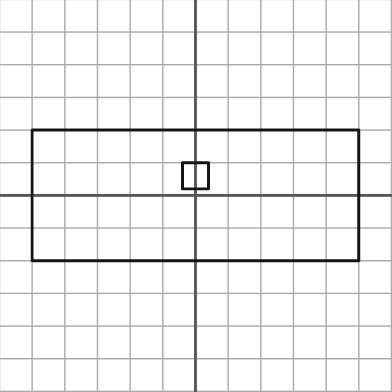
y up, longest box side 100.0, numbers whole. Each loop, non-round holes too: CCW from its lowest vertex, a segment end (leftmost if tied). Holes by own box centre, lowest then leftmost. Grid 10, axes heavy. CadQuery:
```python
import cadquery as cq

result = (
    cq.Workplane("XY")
    .moveTo(-50.0, -20.0)
    .lineTo(50.0, -20.0)
    .lineTo(50.0, 20.0)
    .lineTo(-50.0, 20.0)
    .close()
    .moveTo(-4.0, 2.0)
    .lineTo(4.0, 2.0)
    .lineTo(4.0, 10.0)
    .lineTo(-4.0, 10.0)
    .close()
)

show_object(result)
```